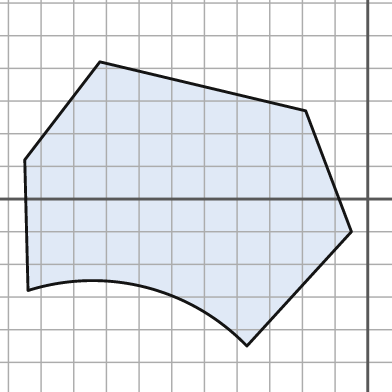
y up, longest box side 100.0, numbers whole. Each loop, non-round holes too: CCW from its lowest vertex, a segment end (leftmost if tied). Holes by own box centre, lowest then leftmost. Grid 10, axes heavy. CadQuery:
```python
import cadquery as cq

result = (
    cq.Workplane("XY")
    .moveTo(-37.0, -45.0)
    .lineTo(-5.0, -10.0)
    .lineTo(-19.0, 27.0)
    .lineTo(-82.0, 42.0)
    .lineTo(-105.0, 12.0)
    .lineTo(-104.0, -28.0)
    .threePointArc((-68.0, -27.0), (-37.0, -45.0))
    .close()
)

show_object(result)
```